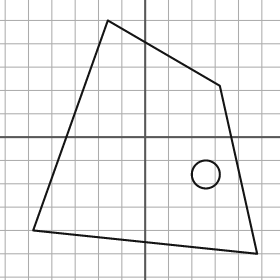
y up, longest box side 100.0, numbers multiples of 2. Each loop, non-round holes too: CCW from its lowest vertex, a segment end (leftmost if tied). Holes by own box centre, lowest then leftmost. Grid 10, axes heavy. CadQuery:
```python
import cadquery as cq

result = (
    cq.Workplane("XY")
    .moveTo(48.0, -50.0)
    .lineTo(32.0, 22.0)
    .lineTo(-16.0, 50.0)
    .lineTo(-48.0, -40.0)
    .close()
    .moveTo(26.0, -16.0)
    .circle(6.0)
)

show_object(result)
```